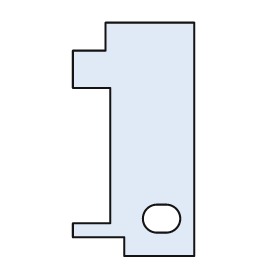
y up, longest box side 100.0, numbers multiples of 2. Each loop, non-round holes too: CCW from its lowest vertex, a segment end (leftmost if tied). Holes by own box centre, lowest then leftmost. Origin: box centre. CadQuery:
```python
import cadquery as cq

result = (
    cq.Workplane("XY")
    .moveTo(-4.0, -50.0)
    .lineTo(26.0, -50.0)
    .lineTo(26.0, 50.0)
    .lineTo(-12.0, 50.0)
    .lineTo(-12.0, 38.0)
    .lineTo(-26.0, 38.0)
    .lineTo(-26.0, 22.0)
    .lineTo(-10.0, 22.0)
    .lineTo(-10.0, -36.0)
    .lineTo(-26.0, -36.0)
    .lineTo(-26.0, -42.0)
    .lineTo(-4.0, -42.0)
    .close()
    .moveTo(10.0, -40.0)
    .lineTo(14.0, -40.0)
    .threePointArc((20.0, -34.0), (14.0, -28.0))
    .lineTo(10.0, -28.0)
    .threePointArc((4.0, -34.0), (10.0, -40.0))
    .close()
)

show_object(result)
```